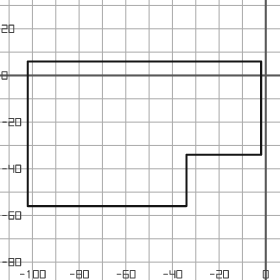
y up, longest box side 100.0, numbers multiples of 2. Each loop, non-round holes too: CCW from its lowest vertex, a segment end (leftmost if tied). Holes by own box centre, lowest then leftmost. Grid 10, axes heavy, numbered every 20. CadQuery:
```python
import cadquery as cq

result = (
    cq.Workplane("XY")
    .moveTo(-102.0, -56.0)
    .lineTo(-34.0, -56.0)
    .lineTo(-34.0, -34.0)
    .lineTo(-2.0, -34.0)
    .lineTo(-2.0, 6.0)
    .lineTo(-102.0, 6.0)
    .close()
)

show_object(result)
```